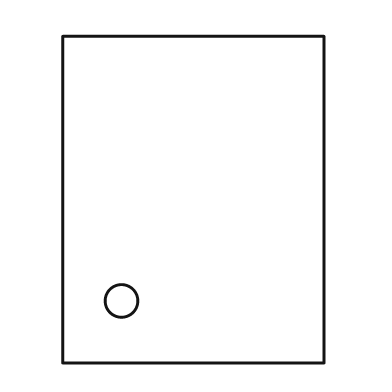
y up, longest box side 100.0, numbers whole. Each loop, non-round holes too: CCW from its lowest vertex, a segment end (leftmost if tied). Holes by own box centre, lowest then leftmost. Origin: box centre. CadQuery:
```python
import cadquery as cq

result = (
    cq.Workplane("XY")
    .moveTo(-40.0, -50.0)
    .lineTo(40.0, -50.0)
    .lineTo(40.0, 50.0)
    .lineTo(-40.0, 50.0)
    .close()
    .moveTo(-22.0, -31.0)
    .circle(5.0)
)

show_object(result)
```